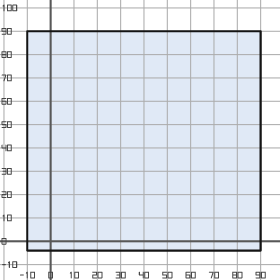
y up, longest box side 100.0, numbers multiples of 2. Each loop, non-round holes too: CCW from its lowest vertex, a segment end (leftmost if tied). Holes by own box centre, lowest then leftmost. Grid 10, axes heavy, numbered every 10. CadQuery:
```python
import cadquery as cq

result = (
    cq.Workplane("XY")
    .moveTo(-10.0, -4.0)
    .lineTo(90.0, -4.0)
    .lineTo(90.0, 90.0)
    .lineTo(-10.0, 90.0)
    .close()
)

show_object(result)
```